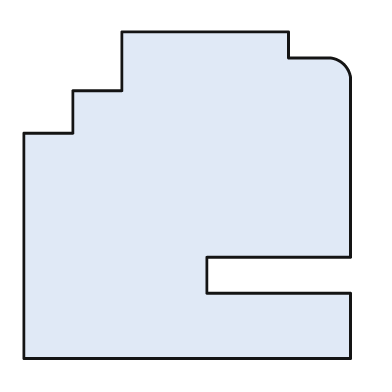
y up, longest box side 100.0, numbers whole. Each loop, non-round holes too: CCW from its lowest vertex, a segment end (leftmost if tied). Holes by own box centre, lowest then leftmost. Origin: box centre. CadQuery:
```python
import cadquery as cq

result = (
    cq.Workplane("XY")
    .moveTo(-50.0, -50.0)
    .lineTo(50.0, -50.0)
    .lineTo(50.0, -30.0)
    .lineTo(6.0, -30.0)
    .lineTo(6.0, -19.0)
    .lineTo(50.0, -19.0)
    .lineTo(50.0, 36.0)
    .threePointArc((48.0, 40.0), (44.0, 42.0))
    .lineTo(31.0, 42.0)
    .lineTo(31.0, 50.0)
    .lineTo(-20.0, 50.0)
    .lineTo(-20.0, 32.0)
    .lineTo(-35.0, 32.0)
    .lineTo(-35.0, 19.0)
    .lineTo(-50.0, 19.0)
    .close()
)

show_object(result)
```